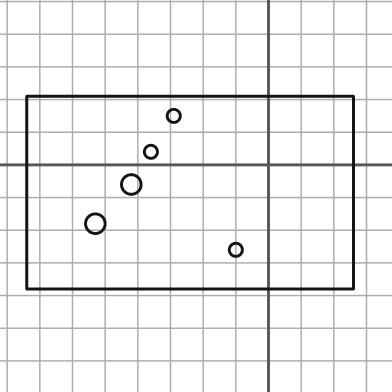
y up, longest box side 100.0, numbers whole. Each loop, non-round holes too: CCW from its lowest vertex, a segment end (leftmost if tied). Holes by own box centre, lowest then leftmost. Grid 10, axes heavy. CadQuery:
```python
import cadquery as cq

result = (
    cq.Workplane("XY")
    .moveTo(-74.0, -38.0)
    .lineTo(26.0, -38.0)
    .lineTo(26.0, 21.0)
    .lineTo(-74.0, 21.0)
    .close()
    .moveTo(-10.0, -26.0)
    .circle(2.0)
    .moveTo(-53.0, -18.0)
    .circle(3.0)
    .moveTo(-42.0, -6.0)
    .circle(3.0)
    .moveTo(-36.0, 4.0)
    .circle(2.0)
    .moveTo(-29.0, 15.0)
    .circle(2.0)
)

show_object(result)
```